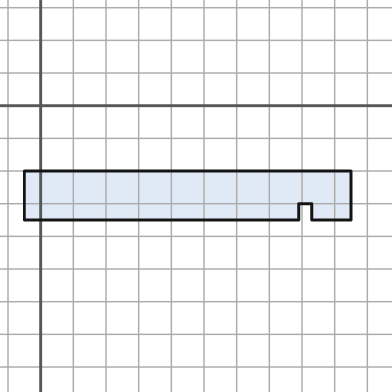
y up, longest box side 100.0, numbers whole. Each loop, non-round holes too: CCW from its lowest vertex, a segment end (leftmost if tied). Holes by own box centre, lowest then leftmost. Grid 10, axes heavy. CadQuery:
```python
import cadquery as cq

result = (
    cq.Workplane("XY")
    .moveTo(-5.0, -35.0)
    .lineTo(79.0, -35.0)
    .lineTo(79.0, -30.0)
    .lineTo(83.0, -30.0)
    .lineTo(83.0, -35.0)
    .lineTo(95.0, -35.0)
    .lineTo(95.0, -20.0)
    .lineTo(-5.0, -20.0)
    .close()
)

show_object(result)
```